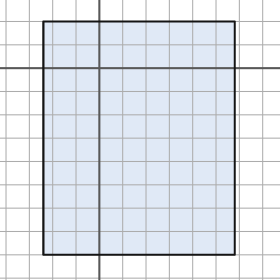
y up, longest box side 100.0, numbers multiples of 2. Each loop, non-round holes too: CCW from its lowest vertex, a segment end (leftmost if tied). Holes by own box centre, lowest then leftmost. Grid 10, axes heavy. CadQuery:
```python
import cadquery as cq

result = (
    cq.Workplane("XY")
    .moveTo(-24.0, -80.0)
    .lineTo(58.0, -80.0)
    .lineTo(58.0, 20.0)
    .lineTo(-24.0, 20.0)
    .close()
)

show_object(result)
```